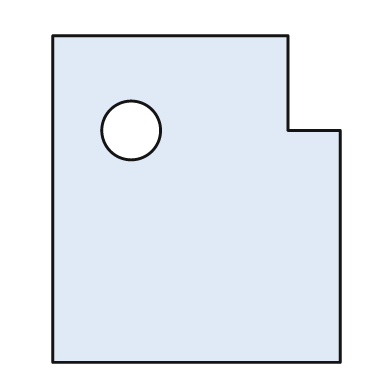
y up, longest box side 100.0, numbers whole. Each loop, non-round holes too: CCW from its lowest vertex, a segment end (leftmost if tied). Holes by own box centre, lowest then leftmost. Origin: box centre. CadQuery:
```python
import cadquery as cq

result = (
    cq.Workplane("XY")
    .moveTo(-44.0, -50.0)
    .lineTo(44.0, -50.0)
    .lineTo(44.0, 21.0)
    .lineTo(28.0, 21.0)
    .lineTo(28.0, 50.0)
    .lineTo(-44.0, 50.0)
    .close()
    .moveTo(-20.0, 21.0)
    .circle(9.0)
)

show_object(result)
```